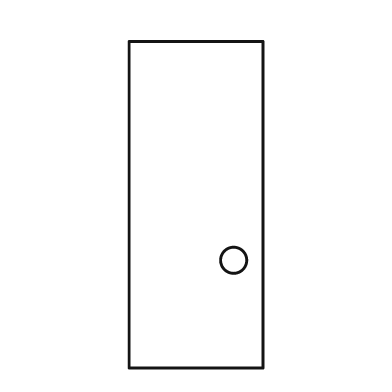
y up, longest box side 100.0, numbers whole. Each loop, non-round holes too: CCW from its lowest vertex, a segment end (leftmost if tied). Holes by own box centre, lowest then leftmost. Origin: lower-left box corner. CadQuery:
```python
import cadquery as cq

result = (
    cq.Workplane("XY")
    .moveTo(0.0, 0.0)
    .lineTo(41.0, 0.0)
    .lineTo(41.0, 100.0)
    .lineTo(0.0, 100.0)
    .close()
    .moveTo(32.0, 33.0)
    .circle(4.0)
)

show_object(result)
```